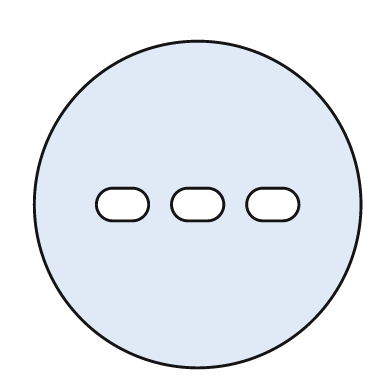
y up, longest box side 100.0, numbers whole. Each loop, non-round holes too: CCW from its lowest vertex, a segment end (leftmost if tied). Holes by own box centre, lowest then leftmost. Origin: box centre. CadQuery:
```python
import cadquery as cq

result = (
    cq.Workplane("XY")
    .moveTo(0.0, 0.0)
    .circle(50.0)
    .moveTo(-26.0, -5.0)
    .lineTo(-20.0, -5.0)
    .threePointArc((-15.0, 0.0), (-20.0, 5.0))
    .lineTo(-26.0, 5.0)
    .threePointArc((-31.0, 0.0), (-26.0, -5.0))
    .close()
    .moveTo(-3.0, -5.0)
    .lineTo(3.0, -5.0)
    .threePointArc((8.0, 0.0), (3.0, 5.0))
    .lineTo(-3.0, 5.0)
    .threePointArc((-8.0, 0.0), (-3.0, -5.0))
    .close()
    .moveTo(20.0, -5.0)
    .lineTo(26.0, -5.0)
    .threePointArc((31.0, 0.0), (26.0, 5.0))
    .lineTo(20.0, 5.0)
    .threePointArc((15.0, 0.0), (20.0, -5.0))
    .close()
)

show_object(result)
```